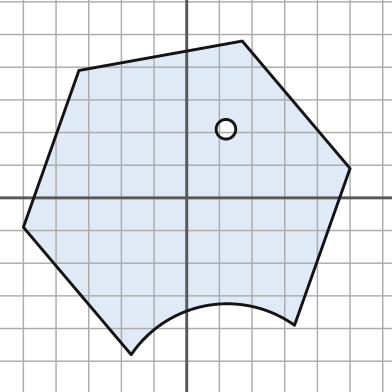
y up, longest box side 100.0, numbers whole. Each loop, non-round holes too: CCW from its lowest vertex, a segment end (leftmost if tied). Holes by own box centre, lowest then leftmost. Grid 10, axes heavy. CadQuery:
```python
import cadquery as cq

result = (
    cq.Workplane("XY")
    .moveTo(-17.0, -48.0)
    .threePointArc((6.0, -33.0), (33.0, -39.0))
    .lineTo(50.0, 9.0)
    .lineTo(17.0, 48.0)
    .lineTo(-33.0, 39.0)
    .lineTo(-50.0, -9.0)
    .close()
    .moveTo(12.0, 21.0)
    .circle(3.0)
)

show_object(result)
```